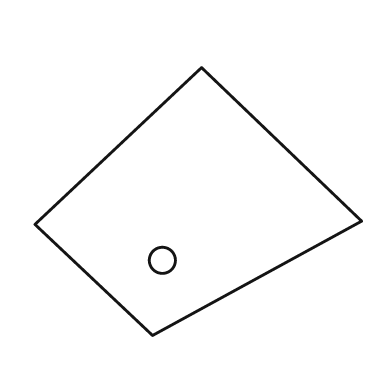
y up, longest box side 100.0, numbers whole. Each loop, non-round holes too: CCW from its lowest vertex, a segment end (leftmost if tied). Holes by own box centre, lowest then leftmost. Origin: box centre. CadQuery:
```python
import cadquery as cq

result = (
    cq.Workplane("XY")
    .moveTo(-14.0, -41.0)
    .lineTo(50.0, -6.0)
    .lineTo(1.0, 41.0)
    .lineTo(-50.0, -7.0)
    .close()
    .moveTo(-11.0, -18.0)
    .circle(4.0)
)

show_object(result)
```